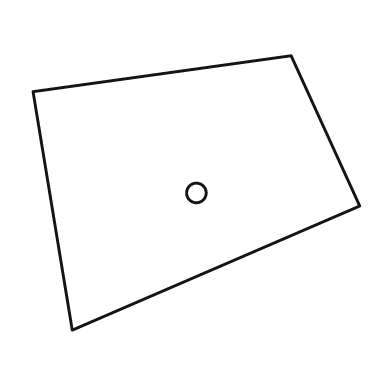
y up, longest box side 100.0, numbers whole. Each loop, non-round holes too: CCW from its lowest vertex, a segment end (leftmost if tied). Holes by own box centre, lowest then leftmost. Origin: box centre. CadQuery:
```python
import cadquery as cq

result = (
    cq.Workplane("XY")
    .moveTo(-38.0, -42.0)
    .lineTo(50.0, -4.0)
    .lineTo(29.0, 42.0)
    .lineTo(-50.0, 31.0)
    .close()
    .moveTo(0.0, 0.0)
    .circle(3.0)
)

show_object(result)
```